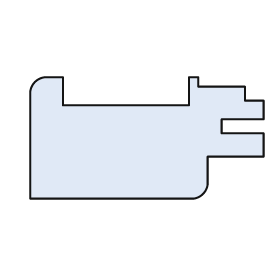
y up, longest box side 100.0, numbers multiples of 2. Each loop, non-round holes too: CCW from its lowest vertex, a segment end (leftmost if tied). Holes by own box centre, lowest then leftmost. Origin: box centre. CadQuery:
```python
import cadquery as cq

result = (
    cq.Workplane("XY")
    .moveTo(-50.0, -26.0)
    .lineTo(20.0, -26.0)
    .threePointArc((24.0, -24.0), (26.0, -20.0))
    .lineTo(26.0, -8.0)
    .lineTo(50.0, -8.0)
    .lineTo(50.0, 2.0)
    .lineTo(32.0, 2.0)
    .lineTo(32.0, 8.0)
    .lineTo(50.0, 8.0)
    .lineTo(50.0, 16.0)
    .lineTo(42.0, 16.0)
    .lineTo(42.0, 22.0)
    .lineTo(22.0, 22.0)
    .lineTo(22.0, 26.0)
    .lineTo(18.0, 26.0)
    .lineTo(18.0, 14.0)
    .lineTo(-36.0, 14.0)
    .lineTo(-36.0, 26.0)
    .lineTo(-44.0, 26.0)
    .threePointArc((-48.0, 24.0), (-50.0, 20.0))
    .close()
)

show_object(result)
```